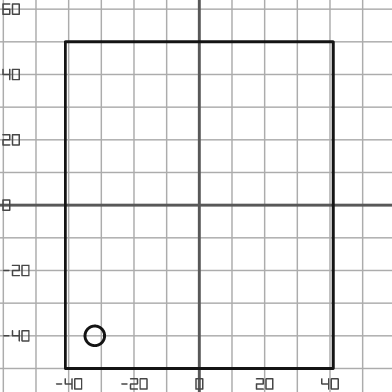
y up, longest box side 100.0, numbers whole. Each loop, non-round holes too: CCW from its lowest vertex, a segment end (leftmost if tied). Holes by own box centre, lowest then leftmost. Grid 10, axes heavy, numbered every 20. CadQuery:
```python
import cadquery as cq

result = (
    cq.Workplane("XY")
    .moveTo(-41.0, -50.0)
    .lineTo(41.0, -50.0)
    .lineTo(41.0, 50.0)
    .lineTo(-41.0, 50.0)
    .close()
    .moveTo(-32.0, -40.0)
    .circle(3.0)
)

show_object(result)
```